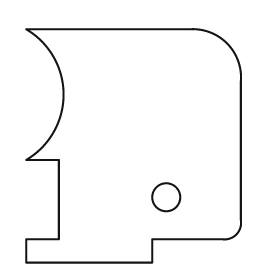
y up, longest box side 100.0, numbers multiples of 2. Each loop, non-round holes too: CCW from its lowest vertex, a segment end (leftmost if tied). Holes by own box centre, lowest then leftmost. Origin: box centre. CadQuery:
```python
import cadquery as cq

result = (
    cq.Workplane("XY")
    .moveTo(-46.0, -50.0)
    .lineTo(8.0, -50.0)
    .lineTo(8.0, -40.0)
    .lineTo(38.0, -40.0)
    .threePointArc((44.0, -38.0), (46.0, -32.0))
    .lineTo(46.0, 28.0)
    .threePointArc((40.0, 44.0), (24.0, 50.0))
    .lineTo(-46.0, 50.0)
    .threePointArc((-30.0, 22.0), (-46.0, -6.0))
    .lineTo(-32.0, -6.0)
    .lineTo(-32.0, -40.0)
    .lineTo(-46.0, -40.0)
    .close()
    .moveTo(14.0, -22.0)
    .circle(6.0)
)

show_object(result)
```